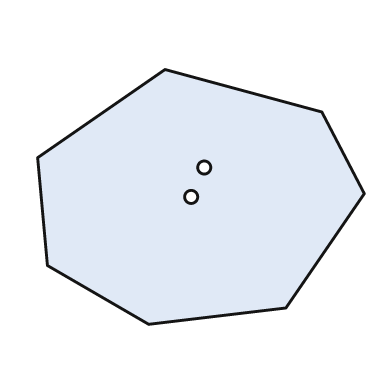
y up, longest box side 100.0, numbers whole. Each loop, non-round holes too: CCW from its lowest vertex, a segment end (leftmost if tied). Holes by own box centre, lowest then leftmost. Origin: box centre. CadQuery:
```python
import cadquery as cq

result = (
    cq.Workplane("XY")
    .moveTo(-16.0, -39.0)
    .lineTo(26.0, -34.0)
    .lineTo(50.0, 1.0)
    .lineTo(37.0, 26.0)
    .lineTo(-11.0, 39.0)
    .lineTo(-50.0, 12.0)
    .lineTo(-47.0, -21.0)
    .close()
    .moveTo(-3.0, 0.0)
    .circle(2.0)
    .moveTo(1.0, 9.0)
    .circle(2.0)
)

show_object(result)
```